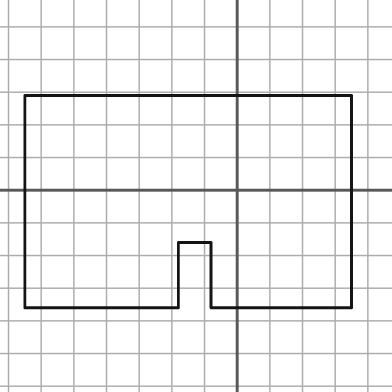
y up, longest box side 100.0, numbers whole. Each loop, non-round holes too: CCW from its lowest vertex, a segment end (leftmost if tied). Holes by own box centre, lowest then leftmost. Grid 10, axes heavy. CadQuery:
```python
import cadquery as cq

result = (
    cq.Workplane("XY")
    .moveTo(-65.0, -36.0)
    .lineTo(-18.0, -36.0)
    .lineTo(-18.0, -16.0)
    .lineTo(-8.0, -16.0)
    .lineTo(-8.0, -36.0)
    .lineTo(35.0, -36.0)
    .lineTo(35.0, 29.0)
    .lineTo(-65.0, 29.0)
    .close()
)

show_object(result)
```